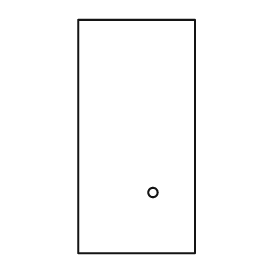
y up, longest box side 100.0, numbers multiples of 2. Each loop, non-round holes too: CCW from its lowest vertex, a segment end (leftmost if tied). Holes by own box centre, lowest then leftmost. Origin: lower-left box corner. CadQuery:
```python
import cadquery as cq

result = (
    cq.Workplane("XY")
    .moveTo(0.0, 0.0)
    .lineTo(50.0, 0.0)
    .lineTo(50.0, 100.0)
    .lineTo(0.0, 100.0)
    .close()
    .moveTo(32.0, 26.0)
    .circle(2.0)
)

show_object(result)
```